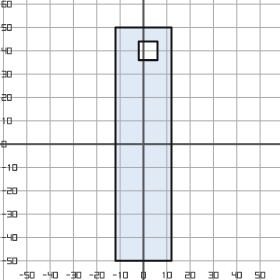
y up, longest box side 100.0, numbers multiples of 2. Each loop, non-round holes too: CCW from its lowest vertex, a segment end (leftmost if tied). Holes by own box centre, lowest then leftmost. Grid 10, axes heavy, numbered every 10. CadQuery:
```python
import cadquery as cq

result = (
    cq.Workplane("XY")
    .moveTo(-12.0, -50.0)
    .lineTo(12.0, -50.0)
    .lineTo(12.0, 50.0)
    .lineTo(-12.0, 50.0)
    .close()
    .moveTo(-2.0, 36.0)
    .lineTo(6.0, 36.0)
    .lineTo(6.0, 44.0)
    .lineTo(-2.0, 44.0)
    .close()
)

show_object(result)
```